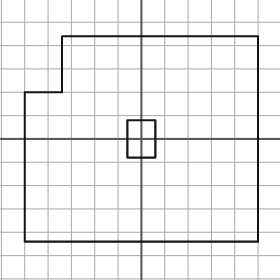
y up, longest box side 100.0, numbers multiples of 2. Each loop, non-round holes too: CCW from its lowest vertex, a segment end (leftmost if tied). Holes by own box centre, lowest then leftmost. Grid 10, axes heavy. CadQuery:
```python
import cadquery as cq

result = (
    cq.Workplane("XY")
    .moveTo(-50.0, -44.0)
    .lineTo(50.0, -44.0)
    .lineTo(50.0, 44.0)
    .lineTo(-34.0, 44.0)
    .lineTo(-34.0, 20.0)
    .lineTo(-50.0, 20.0)
    .close()
    .moveTo(-6.0, -8.0)
    .lineTo(6.0, -8.0)
    .lineTo(6.0, 8.0)
    .lineTo(-6.0, 8.0)
    .close()
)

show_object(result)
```